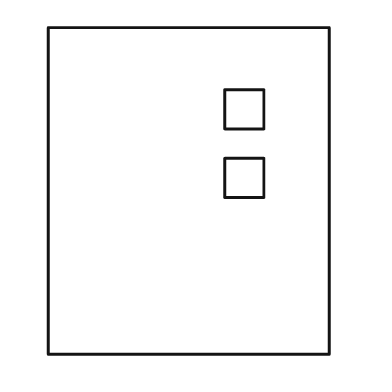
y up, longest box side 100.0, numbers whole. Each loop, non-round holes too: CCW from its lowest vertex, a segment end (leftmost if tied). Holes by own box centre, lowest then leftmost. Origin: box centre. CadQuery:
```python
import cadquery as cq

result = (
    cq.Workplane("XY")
    .moveTo(-43.0, -50.0)
    .lineTo(43.0, -50.0)
    .lineTo(43.0, 50.0)
    .lineTo(-43.0, 50.0)
    .close()
    .moveTo(11.0, -2.0)
    .lineTo(23.0, -2.0)
    .lineTo(23.0, 10.0)
    .lineTo(11.0, 10.0)
    .close()
    .moveTo(11.0, 19.0)
    .lineTo(23.0, 19.0)
    .lineTo(23.0, 31.0)
    .lineTo(11.0, 31.0)
    .close()
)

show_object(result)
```